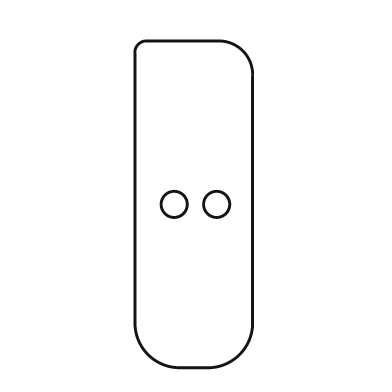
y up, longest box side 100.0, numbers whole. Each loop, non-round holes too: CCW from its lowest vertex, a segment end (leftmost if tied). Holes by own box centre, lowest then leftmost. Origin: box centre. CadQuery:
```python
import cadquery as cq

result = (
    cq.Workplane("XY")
    .moveTo(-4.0, -50.0)
    .lineTo(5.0, -50.0)
    .threePointArc((14.0, -46.0), (18.0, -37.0))
    .lineTo(18.0, 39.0)
    .threePointArc((15.0, 47.0), (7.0, 50.0))
    .lineTo(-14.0, 50.0)
    .threePointArc((-17.0, 49.0), (-18.0, 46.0))
    .lineTo(-18.0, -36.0)
    .threePointArc((-14.0, -46.0), (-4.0, -50.0))
    .close()
    .moveTo(-6.0, 0.0)
    .circle(4.0)
    .moveTo(7.0, 0.0)
    .circle(4.0)
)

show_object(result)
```